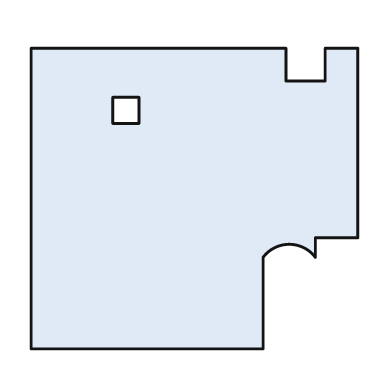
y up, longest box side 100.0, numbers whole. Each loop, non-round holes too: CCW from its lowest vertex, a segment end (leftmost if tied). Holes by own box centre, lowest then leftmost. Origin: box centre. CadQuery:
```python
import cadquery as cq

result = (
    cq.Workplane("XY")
    .moveTo(-50.0, -46.0)
    .lineTo(21.0, -46.0)
    .lineTo(21.0, -18.0)
    .threePointArc((29.0, -14.0), (37.0, -18.0))
    .lineTo(37.0, -12.0)
    .lineTo(50.0, -12.0)
    .lineTo(50.0, 46.0)
    .lineTo(40.0, 46.0)
    .lineTo(40.0, 36.0)
    .lineTo(28.0, 36.0)
    .lineTo(28.0, 46.0)
    .lineTo(-50.0, 46.0)
    .close()
    .moveTo(-25.0, 23.0)
    .lineTo(-17.0, 23.0)
    .lineTo(-17.0, 31.0)
    .lineTo(-25.0, 31.0)
    .close()
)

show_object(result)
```